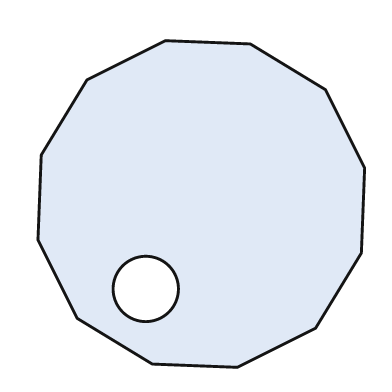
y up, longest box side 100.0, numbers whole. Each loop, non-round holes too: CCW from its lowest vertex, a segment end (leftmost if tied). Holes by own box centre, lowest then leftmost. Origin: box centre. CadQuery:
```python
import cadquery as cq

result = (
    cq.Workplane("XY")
    .moveTo(11.0, -50.0)
    .lineTo(35.0, -38.0)
    .lineTo(49.0, -15.0)
    .lineTo(50.0, 11.0)
    .lineTo(38.0, 35.0)
    .lineTo(15.0, 49.0)
    .lineTo(-11.0, 50.0)
    .lineTo(-35.0, 38.0)
    .lineTo(-49.0, 15.0)
    .lineTo(-50.0, -11.0)
    .lineTo(-38.0, -35.0)
    .lineTo(-15.0, -49.0)
    .close()
    .moveTo(-17.0, -26.0)
    .circle(10.0)
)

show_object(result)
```